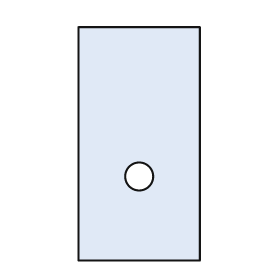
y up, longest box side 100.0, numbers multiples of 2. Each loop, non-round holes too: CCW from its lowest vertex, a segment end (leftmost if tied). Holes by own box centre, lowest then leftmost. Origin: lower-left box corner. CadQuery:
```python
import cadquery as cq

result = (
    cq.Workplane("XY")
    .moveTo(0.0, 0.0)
    .lineTo(52.0, 0.0)
    .lineTo(52.0, 100.0)
    .lineTo(0.0, 100.0)
    .close()
    .moveTo(26.0, 36.0)
    .circle(6.0)
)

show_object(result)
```